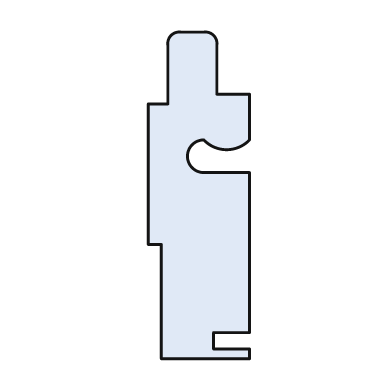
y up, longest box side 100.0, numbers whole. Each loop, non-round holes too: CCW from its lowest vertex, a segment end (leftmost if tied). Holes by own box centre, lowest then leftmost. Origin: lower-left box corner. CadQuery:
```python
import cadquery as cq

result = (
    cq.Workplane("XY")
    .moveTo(4.0, 0.0)
    .lineTo(31.0, 0.0)
    .lineTo(31.0, 3.0)
    .lineTo(20.0, 3.0)
    .lineTo(20.0, 8.0)
    .lineTo(31.0, 8.0)
    .lineTo(31.0, 57.0)
    .lineTo(17.0, 57.0)
    .threePointArc((12.0, 62.0), (17.0, 67.0))
    .threePointArc((24.0, 64.0), (31.0, 67.0))
    .lineTo(31.0, 81.0)
    .lineTo(21.0, 81.0)
    .lineTo(21.0, 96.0)
    .threePointArc((20.0, 99.0), (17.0, 100.0))
    .lineTo(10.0, 100.0)
    .threePointArc((7.0, 99.0), (6.0, 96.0))
    .lineTo(6.0, 78.0)
    .lineTo(0.0, 78.0)
    .lineTo(0.0, 35.0)
    .lineTo(4.0, 35.0)
    .close()
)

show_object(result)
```